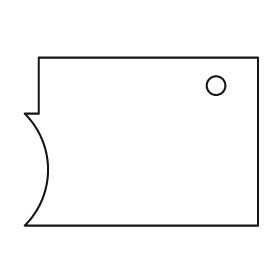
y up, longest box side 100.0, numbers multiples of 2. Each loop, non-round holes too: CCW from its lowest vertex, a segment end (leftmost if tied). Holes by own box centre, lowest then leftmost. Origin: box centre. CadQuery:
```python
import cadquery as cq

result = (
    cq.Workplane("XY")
    .moveTo(-50.0, -36.0)
    .lineTo(50.0, -36.0)
    .lineTo(50.0, 36.0)
    .lineTo(-44.0, 36.0)
    .lineTo(-44.0, 12.0)
    .lineTo(-50.0, 12.0)
    .threePointArc((-40.0, -12.0), (-50.0, -36.0))
    .close()
    .moveTo(32.0, 24.0)
    .circle(4.0)
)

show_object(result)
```